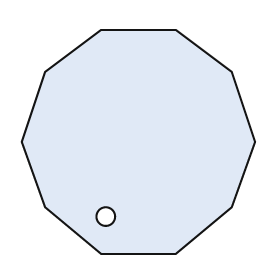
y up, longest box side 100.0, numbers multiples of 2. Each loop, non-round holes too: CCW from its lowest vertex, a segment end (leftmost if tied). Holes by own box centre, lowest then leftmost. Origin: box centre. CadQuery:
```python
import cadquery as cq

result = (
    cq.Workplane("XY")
    .moveTo(-16.0, -48.0)
    .lineTo(16.0, -48.0)
    .lineTo(40.0, -28.0)
    .lineTo(50.0, 0.0)
    .lineTo(40.0, 30.0)
    .lineTo(16.0, 48.0)
    .lineTo(-16.0, 48.0)
    .lineTo(-40.0, 30.0)
    .lineTo(-50.0, 0.0)
    .lineTo(-40.0, -28.0)
    .close()
    .moveTo(-14.0, -32.0)
    .circle(4.0)
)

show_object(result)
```